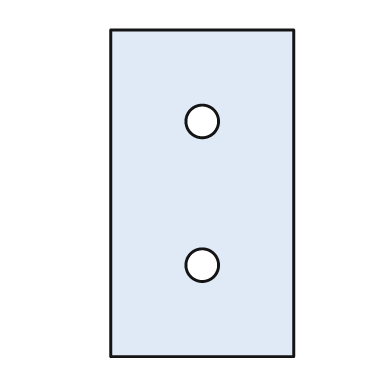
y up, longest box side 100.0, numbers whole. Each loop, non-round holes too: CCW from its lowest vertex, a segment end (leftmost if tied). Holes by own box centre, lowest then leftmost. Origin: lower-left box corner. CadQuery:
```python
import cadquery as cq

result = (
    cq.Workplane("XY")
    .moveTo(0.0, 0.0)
    .lineTo(56.0, 0.0)
    .lineTo(56.0, 100.0)
    .lineTo(0.0, 100.0)
    .close()
    .moveTo(28.0, 28.0)
    .circle(5.0)
    .moveTo(28.0, 72.0)
    .circle(5.0)
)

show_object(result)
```